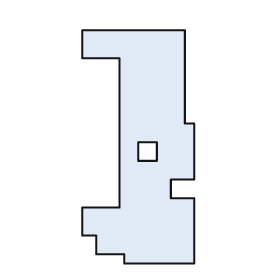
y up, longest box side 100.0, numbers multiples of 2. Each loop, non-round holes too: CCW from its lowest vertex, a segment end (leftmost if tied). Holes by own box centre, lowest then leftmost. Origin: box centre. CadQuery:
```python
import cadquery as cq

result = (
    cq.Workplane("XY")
    .moveTo(-6.0, -50.0)
    .lineTo(24.0, -50.0)
    .lineTo(24.0, -22.0)
    .lineTo(14.0, -22.0)
    .lineTo(14.0, -14.0)
    .lineTo(24.0, -14.0)
    .lineTo(24.0, 10.0)
    .lineTo(20.0, 10.0)
    .lineTo(20.0, 50.0)
    .lineTo(-24.0, 50.0)
    .lineTo(-24.0, 38.0)
    .lineTo(-8.0, 38.0)
    .lineTo(-8.0, -26.0)
    .lineTo(-24.0, -26.0)
    .lineTo(-24.0, -38.0)
    .lineTo(-18.0, -38.0)
    .lineTo(-18.0, -46.0)
    .lineTo(-6.0, -46.0)
    .close()
    .moveTo(0.0, -6.0)
    .lineTo(8.0, -6.0)
    .lineTo(8.0, 2.0)
    .lineTo(0.0, 2.0)
    .close()
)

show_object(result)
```